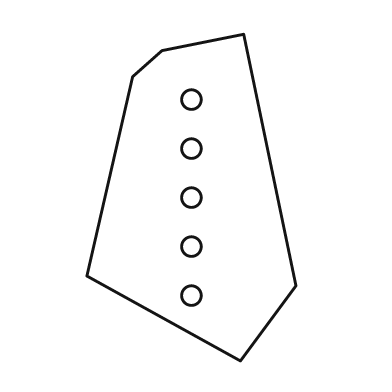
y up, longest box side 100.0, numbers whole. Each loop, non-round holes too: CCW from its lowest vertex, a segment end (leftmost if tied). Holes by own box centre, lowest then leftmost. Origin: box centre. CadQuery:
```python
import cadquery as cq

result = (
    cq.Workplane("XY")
    .moveTo(15.0, -50.0)
    .lineTo(32.0, -27.0)
    .lineTo(16.0, 50.0)
    .lineTo(-9.0, 45.0)
    .lineTo(-18.0, 37.0)
    .lineTo(-32.0, -24.0)
    .close()
    .moveTo(0.0, -30.0)
    .circle(3.0)
    .moveTo(0.0, -15.0)
    .circle(3.0)
    .moveTo(0.0, 0.0)
    .circle(3.0)
    .moveTo(0.0, 15.0)
    .circle(3.0)
    .moveTo(0.0, 30.0)
    .circle(3.0)
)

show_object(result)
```